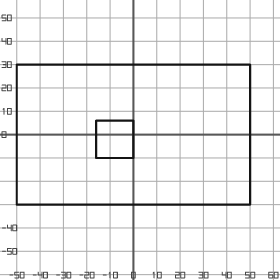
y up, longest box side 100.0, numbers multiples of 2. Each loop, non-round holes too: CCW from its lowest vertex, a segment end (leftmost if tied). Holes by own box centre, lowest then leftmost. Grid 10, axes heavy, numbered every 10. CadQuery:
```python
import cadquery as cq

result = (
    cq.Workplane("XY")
    .moveTo(-50.0, -30.0)
    .lineTo(50.0, -30.0)
    .lineTo(50.0, 30.0)
    .lineTo(-50.0, 30.0)
    .close()
    .moveTo(-16.0, -10.0)
    .lineTo(0.0, -10.0)
    .lineTo(0.0, 6.0)
    .lineTo(-16.0, 6.0)
    .close()
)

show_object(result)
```